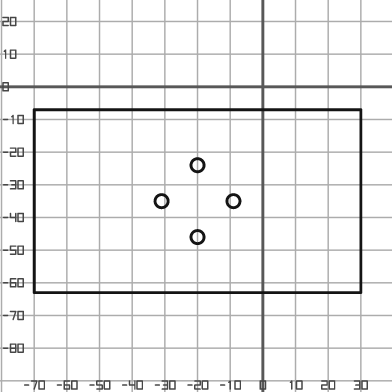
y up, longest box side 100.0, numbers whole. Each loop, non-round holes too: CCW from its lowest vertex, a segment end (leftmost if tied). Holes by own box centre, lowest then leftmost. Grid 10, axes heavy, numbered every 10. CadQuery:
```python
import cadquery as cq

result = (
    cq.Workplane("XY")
    .moveTo(-70.0, -63.0)
    .lineTo(30.0, -63.0)
    .lineTo(30.0, -7.0)
    .lineTo(-70.0, -7.0)
    .close()
    .moveTo(-20.0, -46.0)
    .circle(2.0)
    .moveTo(-31.0, -35.0)
    .circle(2.0)
    .moveTo(-9.0, -35.0)
    .circle(2.0)
    .moveTo(-20.0, -24.0)
    .circle(2.0)
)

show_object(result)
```